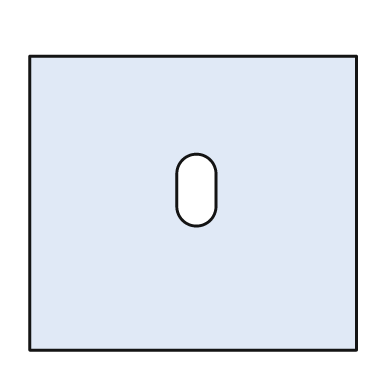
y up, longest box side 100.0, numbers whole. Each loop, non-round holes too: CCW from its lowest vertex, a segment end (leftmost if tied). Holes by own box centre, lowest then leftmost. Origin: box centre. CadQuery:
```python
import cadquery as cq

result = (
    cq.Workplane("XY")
    .moveTo(-50.0, -45.0)
    .lineTo(50.0, -45.0)
    .lineTo(50.0, 45.0)
    .lineTo(-50.0, 45.0)
    .close()
    .moveTo(-5.0, -1.0)
    .threePointArc((1.0, -7.0), (7.0, -1.0))
    .lineTo(7.0, 9.0)
    .threePointArc((1.0, 15.0), (-5.0, 9.0))
    .close()
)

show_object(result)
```